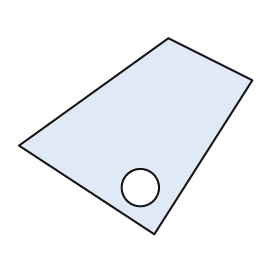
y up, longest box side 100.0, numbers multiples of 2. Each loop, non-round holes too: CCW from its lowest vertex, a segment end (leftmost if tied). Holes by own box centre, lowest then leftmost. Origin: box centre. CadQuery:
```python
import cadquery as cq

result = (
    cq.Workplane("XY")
    .moveTo(8.0, -42.0)
    .lineTo(50.0, 24.0)
    .lineTo(14.0, 42.0)
    .lineTo(-50.0, -4.0)
    .close()
    .moveTo(2.0, -22.0)
    .circle(8.0)
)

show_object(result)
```